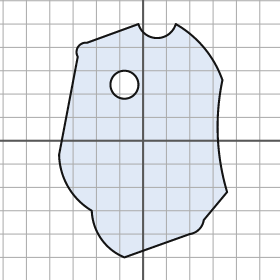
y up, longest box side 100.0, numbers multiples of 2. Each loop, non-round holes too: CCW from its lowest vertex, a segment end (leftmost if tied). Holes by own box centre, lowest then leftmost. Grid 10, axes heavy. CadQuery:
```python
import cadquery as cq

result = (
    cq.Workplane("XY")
    .moveTo(-8.0, -50.0)
    .lineTo(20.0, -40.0)
    .threePointArc((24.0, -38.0), (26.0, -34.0))
    .lineTo(36.0, -22.0)
    .threePointArc((32.0, 2.0), (34.0, 26.0))
    .threePointArc((26.0, 40.0), (14.0, 50.0))
    .threePointArc((6.0, 44.0), (-2.0, 50.0))
    .lineTo(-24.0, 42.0)
    .threePointArc((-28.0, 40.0), (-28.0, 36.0))
    .lineTo(-36.0, -6.0)
    .threePointArc((-32.0, -20.0), (-22.0, -30.0))
    .threePointArc((-18.0, -42.0), (-8.0, -50.0))
    .close()
    .moveTo(-8.0, 24.0)
    .circle(6.0)
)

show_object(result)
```